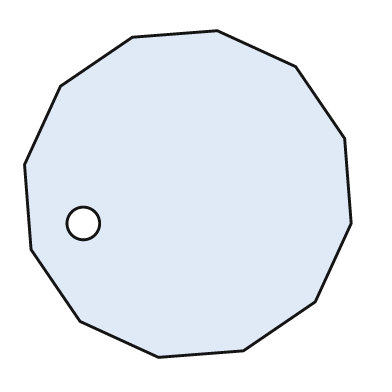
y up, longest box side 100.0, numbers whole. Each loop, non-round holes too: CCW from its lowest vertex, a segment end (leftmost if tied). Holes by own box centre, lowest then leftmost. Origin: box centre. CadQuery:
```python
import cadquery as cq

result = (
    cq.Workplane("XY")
    .moveTo(-9.0, -50.0)
    .lineTo(17.0, -48.0)
    .lineTo(39.0, -33.0)
    .lineTo(50.0, -9.0)
    .lineTo(48.0, 17.0)
    .lineTo(33.0, 39.0)
    .lineTo(9.0, 50.0)
    .lineTo(-17.0, 48.0)
    .lineTo(-39.0, 33.0)
    .lineTo(-50.0, 9.0)
    .lineTo(-48.0, -17.0)
    .lineTo(-33.0, -39.0)
    .close()
    .moveTo(-32.0, -9.0)
    .circle(5.0)
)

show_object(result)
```